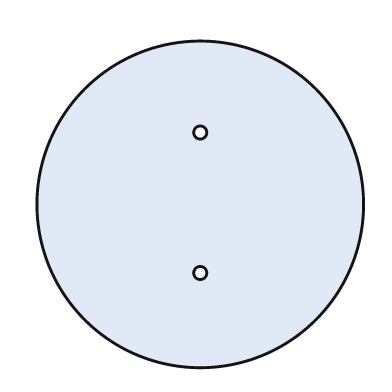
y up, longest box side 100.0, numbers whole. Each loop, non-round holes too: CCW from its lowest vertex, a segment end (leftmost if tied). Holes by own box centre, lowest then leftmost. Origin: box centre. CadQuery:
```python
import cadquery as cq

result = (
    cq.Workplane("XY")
    .moveTo(0.0, 0.0)
    .circle(50.0)
    .moveTo(0.0, -21.0)
    .circle(2.0)
    .moveTo(0.0, 22.0)
    .circle(2.0)
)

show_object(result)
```